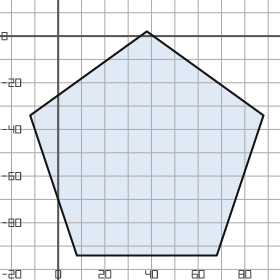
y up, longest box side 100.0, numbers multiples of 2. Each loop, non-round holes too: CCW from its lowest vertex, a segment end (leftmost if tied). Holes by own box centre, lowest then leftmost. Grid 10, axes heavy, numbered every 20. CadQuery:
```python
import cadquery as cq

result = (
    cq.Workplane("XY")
    .moveTo(8.0, -94.0)
    .lineTo(68.0, -94.0)
    .lineTo(88.0, -34.0)
    .lineTo(38.0, 2.0)
    .lineTo(-12.0, -34.0)
    .close()
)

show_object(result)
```